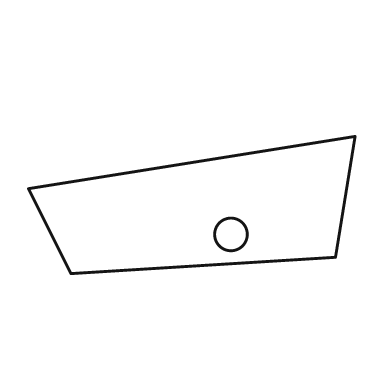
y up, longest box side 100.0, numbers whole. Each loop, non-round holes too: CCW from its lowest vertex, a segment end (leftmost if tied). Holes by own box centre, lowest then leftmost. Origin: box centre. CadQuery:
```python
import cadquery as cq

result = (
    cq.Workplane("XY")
    .moveTo(-37.0, -21.0)
    .lineTo(44.0, -16.0)
    .lineTo(50.0, 21.0)
    .lineTo(-50.0, 5.0)
    .close()
    .moveTo(12.0, -9.0)
    .circle(5.0)
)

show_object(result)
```